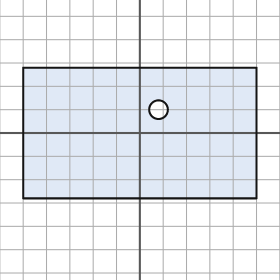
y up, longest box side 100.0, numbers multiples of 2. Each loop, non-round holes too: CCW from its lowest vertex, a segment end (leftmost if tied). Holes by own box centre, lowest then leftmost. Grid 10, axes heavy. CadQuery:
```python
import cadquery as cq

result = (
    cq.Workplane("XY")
    .moveTo(-50.0, -28.0)
    .lineTo(50.0, -28.0)
    .lineTo(50.0, 28.0)
    .lineTo(-50.0, 28.0)
    .close()
    .moveTo(8.0, 10.0)
    .circle(4.0)
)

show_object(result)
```